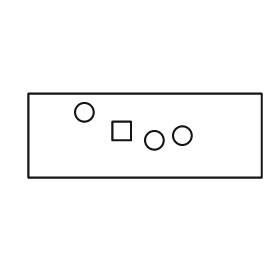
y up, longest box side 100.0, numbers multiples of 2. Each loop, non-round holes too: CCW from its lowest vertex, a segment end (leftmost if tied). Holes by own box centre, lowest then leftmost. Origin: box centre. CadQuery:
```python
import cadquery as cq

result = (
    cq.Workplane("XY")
    .moveTo(-50.0, -18.0)
    .lineTo(50.0, -18.0)
    .lineTo(50.0, 18.0)
    .lineTo(-50.0, 18.0)
    .close()
    .moveTo(4.0, -2.0)
    .circle(4.0)
    .moveTo(16.0, 0.0)
    .circle(4.0)
    .moveTo(-14.0, -2.0)
    .lineTo(-6.0, -2.0)
    .lineTo(-6.0, 6.0)
    .lineTo(-14.0, 6.0)
    .close()
    .moveTo(-26.0, 10.0)
    .circle(4.0)
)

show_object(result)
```